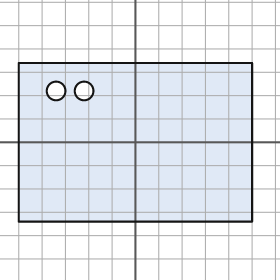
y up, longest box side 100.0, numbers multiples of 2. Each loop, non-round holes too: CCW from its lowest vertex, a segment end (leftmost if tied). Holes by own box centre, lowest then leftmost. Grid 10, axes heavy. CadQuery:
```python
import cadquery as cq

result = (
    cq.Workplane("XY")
    .moveTo(-50.0, -34.0)
    .lineTo(50.0, -34.0)
    .lineTo(50.0, 34.0)
    .lineTo(-50.0, 34.0)
    .close()
    .moveTo(-34.0, 22.0)
    .circle(4.0)
    .moveTo(-22.0, 22.0)
    .circle(4.0)
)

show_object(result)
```